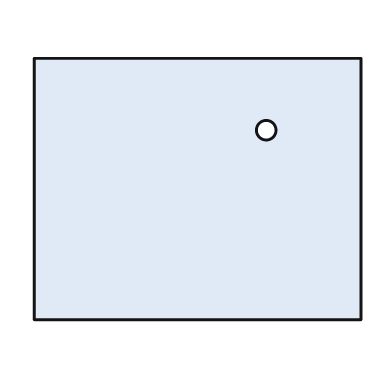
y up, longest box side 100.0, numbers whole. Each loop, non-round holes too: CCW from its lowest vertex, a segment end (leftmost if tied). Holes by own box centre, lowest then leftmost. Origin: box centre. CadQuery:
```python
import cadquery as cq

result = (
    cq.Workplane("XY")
    .moveTo(-50.0, -40.0)
    .lineTo(50.0, -40.0)
    .lineTo(50.0, 40.0)
    .lineTo(-50.0, 40.0)
    .close()
    .moveTo(21.0, 18.0)
    .circle(3.0)
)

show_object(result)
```